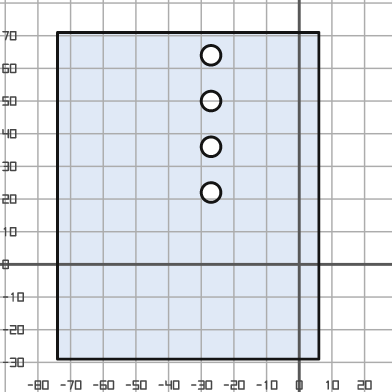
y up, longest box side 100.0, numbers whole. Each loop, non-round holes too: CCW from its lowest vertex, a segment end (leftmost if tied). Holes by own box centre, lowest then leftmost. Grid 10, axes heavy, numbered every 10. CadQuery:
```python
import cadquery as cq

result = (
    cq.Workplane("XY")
    .moveTo(-74.0, -29.0)
    .lineTo(6.0, -29.0)
    .lineTo(6.0, 71.0)
    .lineTo(-74.0, 71.0)
    .close()
    .moveTo(-27.0, 22.0)
    .circle(3.0)
    .moveTo(-27.0, 36.0)
    .circle(3.0)
    .moveTo(-27.0, 50.0)
    .circle(3.0)
    .moveTo(-27.0, 64.0)
    .circle(3.0)
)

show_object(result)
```